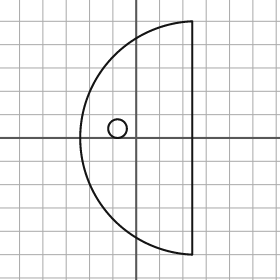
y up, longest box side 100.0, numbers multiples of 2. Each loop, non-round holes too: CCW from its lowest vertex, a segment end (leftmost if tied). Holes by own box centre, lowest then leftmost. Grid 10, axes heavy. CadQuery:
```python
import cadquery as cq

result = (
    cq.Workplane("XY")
    .moveTo(24.0, -50.0)
    .lineTo(24.0, 50.0)
    .threePointArc((-24.0, 0.0), (24.0, -50.0))
    .close()
    .moveTo(-8.0, 4.0)
    .circle(4.0)
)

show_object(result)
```